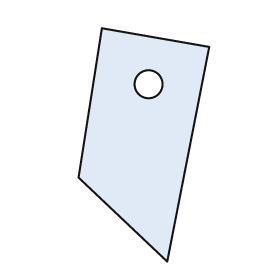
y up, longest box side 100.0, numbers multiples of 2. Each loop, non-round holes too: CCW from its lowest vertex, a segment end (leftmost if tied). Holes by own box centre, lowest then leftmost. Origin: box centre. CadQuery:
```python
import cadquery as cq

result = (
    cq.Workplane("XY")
    .moveTo(10.0, -50.0)
    .lineTo(28.0, 42.0)
    .lineTo(-18.0, 50.0)
    .lineTo(-28.0, -14.0)
    .close()
    .moveTo(2.0, 26.0)
    .circle(6.0)
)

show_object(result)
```